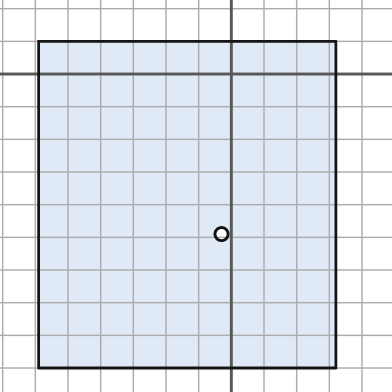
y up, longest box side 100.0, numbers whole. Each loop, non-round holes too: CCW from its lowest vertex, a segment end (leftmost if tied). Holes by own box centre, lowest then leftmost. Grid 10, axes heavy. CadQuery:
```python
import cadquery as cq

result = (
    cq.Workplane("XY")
    .moveTo(-59.0, -90.0)
    .lineTo(32.0, -90.0)
    .lineTo(32.0, 10.0)
    .lineTo(-59.0, 10.0)
    .close()
    .moveTo(-3.0, -49.0)
    .circle(2.0)
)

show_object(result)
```